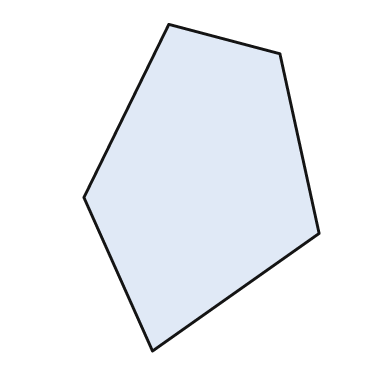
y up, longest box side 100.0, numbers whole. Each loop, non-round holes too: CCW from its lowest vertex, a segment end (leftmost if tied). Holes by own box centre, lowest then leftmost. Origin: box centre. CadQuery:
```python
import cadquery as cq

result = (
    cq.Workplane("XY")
    .moveTo(-15.0, -50.0)
    .lineTo(36.0, -14.0)
    .lineTo(24.0, 41.0)
    .lineTo(-10.0, 50.0)
    .lineTo(-36.0, -3.0)
    .close()
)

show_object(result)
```